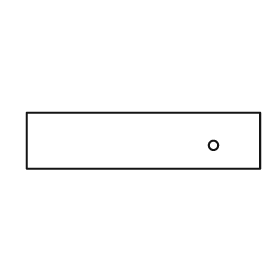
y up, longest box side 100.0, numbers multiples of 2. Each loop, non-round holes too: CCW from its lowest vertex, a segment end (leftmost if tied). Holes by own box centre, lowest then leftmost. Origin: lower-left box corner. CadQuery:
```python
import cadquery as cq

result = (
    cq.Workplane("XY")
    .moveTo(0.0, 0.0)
    .lineTo(100.0, 0.0)
    .lineTo(100.0, 24.0)
    .lineTo(0.0, 24.0)
    .close()
    .moveTo(80.0, 10.0)
    .circle(2.0)
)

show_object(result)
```